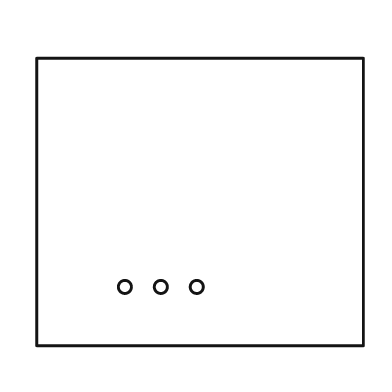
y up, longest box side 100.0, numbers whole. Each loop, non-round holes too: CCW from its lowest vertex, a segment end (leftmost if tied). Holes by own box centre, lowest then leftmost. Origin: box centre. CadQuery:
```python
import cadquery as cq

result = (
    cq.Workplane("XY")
    .moveTo(-50.0, -44.0)
    .lineTo(50.0, -44.0)
    .lineTo(50.0, 44.0)
    .lineTo(-50.0, 44.0)
    .close()
    .moveTo(-23.0, -26.0)
    .circle(2.0)
    .moveTo(-12.0, -26.0)
    .circle(2.0)
    .moveTo(-1.0, -26.0)
    .circle(2.0)
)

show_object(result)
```